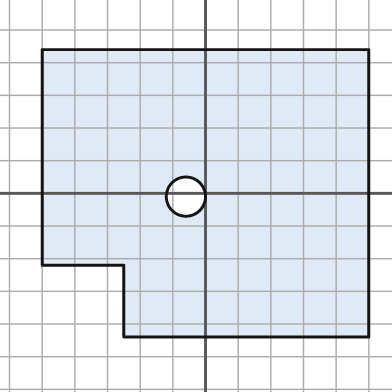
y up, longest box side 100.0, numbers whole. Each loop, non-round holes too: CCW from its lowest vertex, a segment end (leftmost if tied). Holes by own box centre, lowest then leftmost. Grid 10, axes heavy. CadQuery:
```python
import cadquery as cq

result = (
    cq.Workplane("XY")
    .moveTo(-25.0, -44.0)
    .lineTo(50.0, -44.0)
    .lineTo(50.0, 44.0)
    .lineTo(-50.0, 44.0)
    .lineTo(-50.0, -22.0)
    .lineTo(-25.0, -22.0)
    .close()
    .moveTo(-6.0, -1.0)
    .circle(6.0)
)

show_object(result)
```